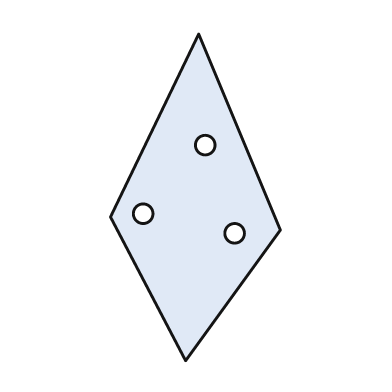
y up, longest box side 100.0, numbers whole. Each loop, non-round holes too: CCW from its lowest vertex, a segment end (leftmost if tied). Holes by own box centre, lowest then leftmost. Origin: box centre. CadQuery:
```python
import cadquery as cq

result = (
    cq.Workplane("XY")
    .moveTo(-3.0, -50.0)
    .lineTo(26.0, -10.0)
    .lineTo(1.0, 50.0)
    .lineTo(-26.0, -6.0)
    .close()
    .moveTo(12.0, -11.0)
    .circle(3.0)
    .moveTo(-16.0, -5.0)
    .circle(3.0)
    .moveTo(3.0, 16.0)
    .circle(3.0)
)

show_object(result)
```